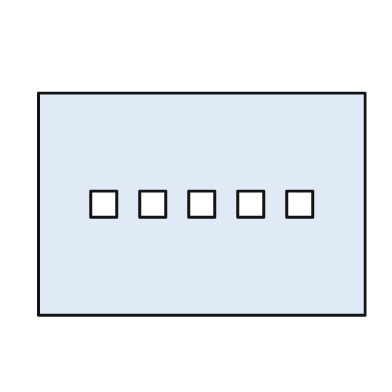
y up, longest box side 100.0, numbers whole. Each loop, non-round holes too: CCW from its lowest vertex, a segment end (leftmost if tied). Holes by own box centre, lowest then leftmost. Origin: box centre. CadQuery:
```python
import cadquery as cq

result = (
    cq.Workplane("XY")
    .moveTo(-50.0, -34.0)
    .lineTo(50.0, -34.0)
    .lineTo(50.0, 34.0)
    .lineTo(-50.0, 34.0)
    .close()
    .moveTo(-34.0, -4.0)
    .lineTo(-26.0, -4.0)
    .lineTo(-26.0, 4.0)
    .lineTo(-34.0, 4.0)
    .close()
    .moveTo(-19.0, -4.0)
    .lineTo(-11.0, -4.0)
    .lineTo(-11.0, 4.0)
    .lineTo(-19.0, 4.0)
    .close()
    .moveTo(-4.0, -4.0)
    .lineTo(4.0, -4.0)
    .lineTo(4.0, 4.0)
    .lineTo(-4.0, 4.0)
    .close()
    .moveTo(11.0, -4.0)
    .lineTo(19.0, -4.0)
    .lineTo(19.0, 4.0)
    .lineTo(11.0, 4.0)
    .close()
    .moveTo(26.0, -4.0)
    .lineTo(34.0, -4.0)
    .lineTo(34.0, 4.0)
    .lineTo(26.0, 4.0)
    .close()
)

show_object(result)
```